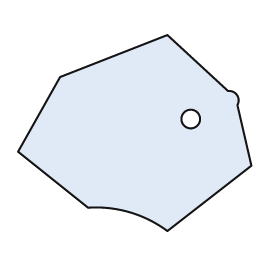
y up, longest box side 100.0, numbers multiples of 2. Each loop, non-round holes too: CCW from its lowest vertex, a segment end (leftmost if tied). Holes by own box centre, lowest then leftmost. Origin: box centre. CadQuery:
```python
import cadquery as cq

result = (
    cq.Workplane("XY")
    .moveTo(14.0, -42.0)
    .lineTo(50.0, -14.0)
    .lineTo(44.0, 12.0)
    .threePointArc((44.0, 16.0), (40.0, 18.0))
    .lineTo(14.0, 42.0)
    .lineTo(-32.0, 24.0)
    .lineTo(-50.0, -8.0)
    .lineTo(-20.0, -32.0)
    .threePointArc((-2.0, -34.0), (14.0, -42.0))
    .close()
    .moveTo(24.0, 6.0)
    .circle(4.0)
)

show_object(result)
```